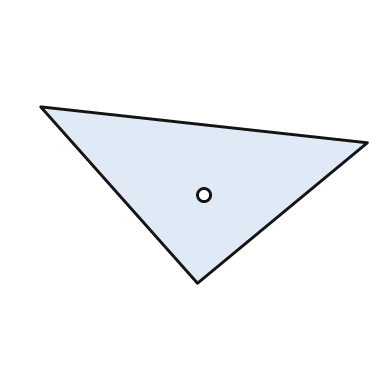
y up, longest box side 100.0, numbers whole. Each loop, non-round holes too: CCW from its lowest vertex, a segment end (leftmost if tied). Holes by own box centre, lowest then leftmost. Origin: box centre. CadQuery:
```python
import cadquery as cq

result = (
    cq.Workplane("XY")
    .moveTo(-2.0, -27.0)
    .lineTo(50.0, 16.0)
    .lineTo(-50.0, 27.0)
    .close()
    .moveTo(0.0, 0.0)
    .circle(2.0)
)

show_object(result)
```